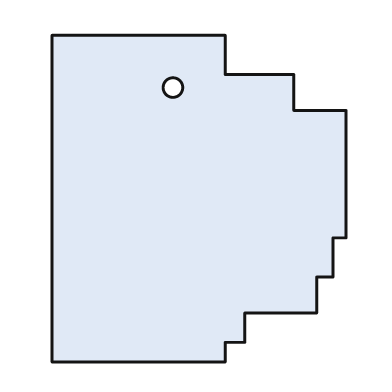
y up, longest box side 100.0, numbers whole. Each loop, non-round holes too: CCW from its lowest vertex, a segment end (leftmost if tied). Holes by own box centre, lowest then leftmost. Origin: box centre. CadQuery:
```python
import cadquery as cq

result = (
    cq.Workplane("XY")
    .moveTo(-45.0, -50.0)
    .lineTo(8.0, -50.0)
    .lineTo(8.0, -44.0)
    .lineTo(14.0, -44.0)
    .lineTo(14.0, -35.0)
    .lineTo(36.0, -35.0)
    .lineTo(36.0, -24.0)
    .lineTo(41.0, -24.0)
    .lineTo(41.0, -12.0)
    .lineTo(45.0, -12.0)
    .lineTo(45.0, 27.0)
    .lineTo(29.0, 27.0)
    .lineTo(29.0, 38.0)
    .lineTo(8.0, 38.0)
    .lineTo(8.0, 50.0)
    .lineTo(-45.0, 50.0)
    .close()
    .moveTo(-8.0, 34.0)
    .circle(3.0)
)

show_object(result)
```